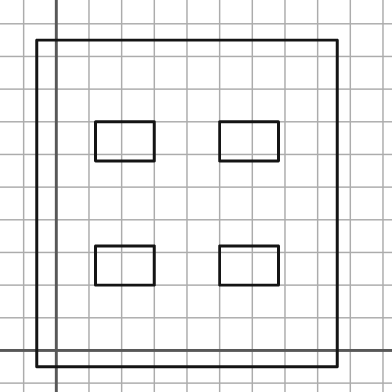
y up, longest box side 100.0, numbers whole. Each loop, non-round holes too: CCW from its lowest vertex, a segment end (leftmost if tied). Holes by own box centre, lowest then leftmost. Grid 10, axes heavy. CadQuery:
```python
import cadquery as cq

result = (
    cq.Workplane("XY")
    .moveTo(-6.0, -5.0)
    .lineTo(86.0, -5.0)
    .lineTo(86.0, 95.0)
    .lineTo(-6.0, 95.0)
    .close()
    .moveTo(12.0, 20.0)
    .lineTo(30.0, 20.0)
    .lineTo(30.0, 32.0)
    .lineTo(12.0, 32.0)
    .close()
    .moveTo(50.0, 20.0)
    .lineTo(68.0, 20.0)
    .lineTo(68.0, 32.0)
    .lineTo(50.0, 32.0)
    .close()
    .moveTo(12.0, 58.0)
    .lineTo(30.0, 58.0)
    .lineTo(30.0, 70.0)
    .lineTo(12.0, 70.0)
    .close()
    .moveTo(50.0, 58.0)
    .lineTo(68.0, 58.0)
    .lineTo(68.0, 70.0)
    .lineTo(50.0, 70.0)
    .close()
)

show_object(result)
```